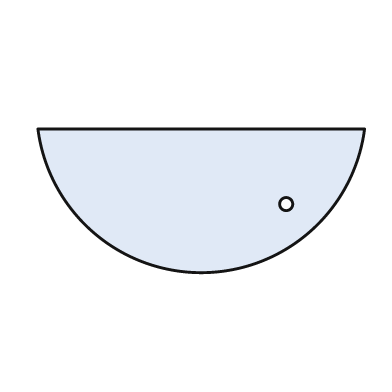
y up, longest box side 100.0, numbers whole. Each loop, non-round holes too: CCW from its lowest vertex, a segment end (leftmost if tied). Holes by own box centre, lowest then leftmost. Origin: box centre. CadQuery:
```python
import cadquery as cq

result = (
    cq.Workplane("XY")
    .moveTo(-50.0, 22.0)
    .threePointArc((0.0, -22.0), (50.0, 22.0))
    .close()
    .moveTo(26.0, -1.0)
    .circle(2.0)
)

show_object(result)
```